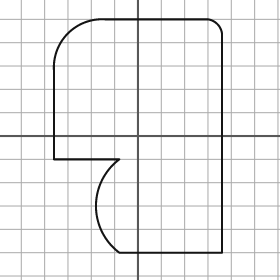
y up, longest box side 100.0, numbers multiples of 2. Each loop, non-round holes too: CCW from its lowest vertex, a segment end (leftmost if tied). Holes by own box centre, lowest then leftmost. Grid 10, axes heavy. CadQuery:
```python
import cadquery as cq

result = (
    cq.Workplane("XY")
    .moveTo(-8.0, -50.0)
    .lineTo(36.0, -50.0)
    .lineTo(36.0, 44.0)
    .threePointArc((34.0, 48.0), (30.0, 50.0))
    .lineTo(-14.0, 50.0)
    .threePointArc((-30.0, 44.0), (-36.0, 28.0))
    .lineTo(-36.0, -10.0)
    .lineTo(-8.0, -10.0)
    .threePointArc((-18.0, -30.0), (-8.0, -50.0))
    .close()
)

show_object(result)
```